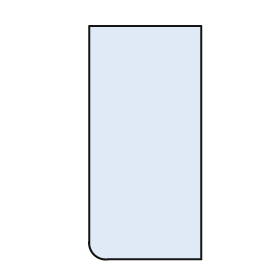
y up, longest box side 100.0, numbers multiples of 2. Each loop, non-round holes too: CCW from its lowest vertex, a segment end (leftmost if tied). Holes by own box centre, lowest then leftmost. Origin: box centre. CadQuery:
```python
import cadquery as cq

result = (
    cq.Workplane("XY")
    .moveTo(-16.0, -50.0)
    .lineTo(24.0, -50.0)
    .lineTo(24.0, 50.0)
    .lineTo(-24.0, 50.0)
    .lineTo(-24.0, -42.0)
    .threePointArc((-22.0, -48.0), (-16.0, -50.0))
    .close()
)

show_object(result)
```